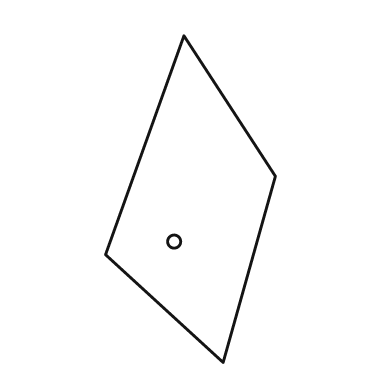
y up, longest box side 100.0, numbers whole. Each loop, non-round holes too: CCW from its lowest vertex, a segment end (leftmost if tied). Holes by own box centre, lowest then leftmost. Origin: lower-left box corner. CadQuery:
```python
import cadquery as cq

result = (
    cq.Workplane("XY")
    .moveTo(36.0, 0.0)
    .lineTo(52.0, 57.0)
    .lineTo(24.0, 100.0)
    .lineTo(0.0, 33.0)
    .close()
    .moveTo(21.0, 37.0)
    .circle(2.0)
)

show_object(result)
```